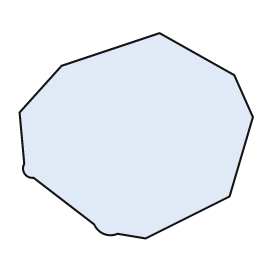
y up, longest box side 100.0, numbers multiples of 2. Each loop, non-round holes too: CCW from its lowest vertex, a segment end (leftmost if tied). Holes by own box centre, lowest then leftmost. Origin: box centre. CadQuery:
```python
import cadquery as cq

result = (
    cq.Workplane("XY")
    .moveTo(4.0, -44.0)
    .lineTo(40.0, -26.0)
    .lineTo(50.0, 8.0)
    .lineTo(42.0, 26.0)
    .lineTo(10.0, 44.0)
    .lineTo(-32.0, 30.0)
    .lineTo(-50.0, 10.0)
    .lineTo(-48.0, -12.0)
    .threePointArc((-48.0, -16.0), (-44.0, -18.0))
    .lineTo(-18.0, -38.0)
    .threePointArc((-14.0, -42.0), (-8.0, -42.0))
    .close()
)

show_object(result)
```